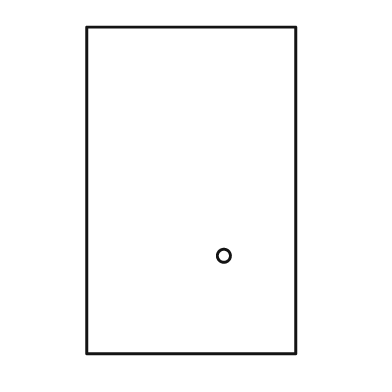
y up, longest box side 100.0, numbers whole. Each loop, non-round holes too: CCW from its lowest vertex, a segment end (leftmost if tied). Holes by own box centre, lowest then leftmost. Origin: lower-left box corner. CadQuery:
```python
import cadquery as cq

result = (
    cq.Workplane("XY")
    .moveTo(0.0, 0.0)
    .lineTo(64.0, 0.0)
    .lineTo(64.0, 100.0)
    .lineTo(0.0, 100.0)
    .close()
    .moveTo(42.0, 30.0)
    .circle(2.0)
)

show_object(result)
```